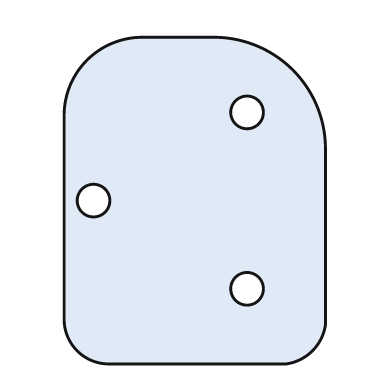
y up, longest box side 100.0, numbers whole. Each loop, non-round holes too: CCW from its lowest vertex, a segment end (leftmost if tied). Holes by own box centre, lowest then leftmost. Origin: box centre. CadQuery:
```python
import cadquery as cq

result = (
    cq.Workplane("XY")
    .moveTo(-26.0, -50.0)
    .lineTo(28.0, -50.0)
    .threePointArc((36.0, -46.0), (40.0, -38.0))
    .lineTo(40.0, 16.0)
    .threePointArc((30.0, 40.0), (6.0, 50.0))
    .lineTo(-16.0, 50.0)
    .threePointArc((-33.0, 43.0), (-40.0, 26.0))
    .lineTo(-40.0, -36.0)
    .threePointArc((-36.0, -46.0), (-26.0, -50.0))
    .close()
    .moveTo(16.0, -27.0)
    .circle(5.0)
    .moveTo(-31.0, 0.0)
    .circle(5.0)
    .moveTo(16.0, 27.0)
    .circle(5.0)
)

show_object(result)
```